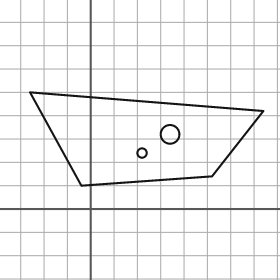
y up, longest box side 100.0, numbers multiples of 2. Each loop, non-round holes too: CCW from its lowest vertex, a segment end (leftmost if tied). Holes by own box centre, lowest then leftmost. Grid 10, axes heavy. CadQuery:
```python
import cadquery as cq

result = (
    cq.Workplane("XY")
    .moveTo(-4.0, 10.0)
    .lineTo(52.0, 14.0)
    .lineTo(74.0, 42.0)
    .lineTo(-26.0, 50.0)
    .close()
    .moveTo(22.0, 24.0)
    .circle(2.0)
    .moveTo(34.0, 32.0)
    .circle(4.0)
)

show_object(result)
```